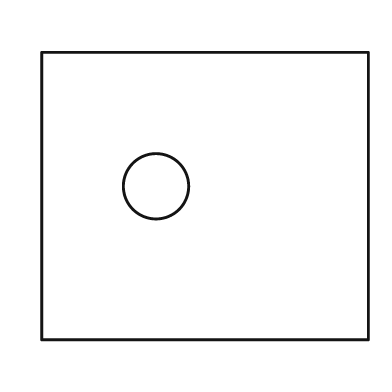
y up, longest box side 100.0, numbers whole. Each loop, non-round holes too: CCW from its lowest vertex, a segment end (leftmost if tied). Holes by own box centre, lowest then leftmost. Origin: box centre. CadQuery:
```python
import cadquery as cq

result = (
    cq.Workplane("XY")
    .moveTo(-50.0, -44.0)
    .lineTo(50.0, -44.0)
    .lineTo(50.0, 44.0)
    .lineTo(-50.0, 44.0)
    .close()
    .moveTo(-15.0, 3.0)
    .circle(10.0)
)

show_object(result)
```